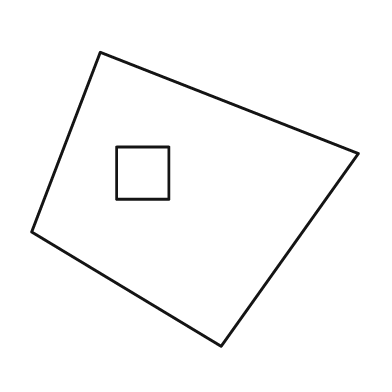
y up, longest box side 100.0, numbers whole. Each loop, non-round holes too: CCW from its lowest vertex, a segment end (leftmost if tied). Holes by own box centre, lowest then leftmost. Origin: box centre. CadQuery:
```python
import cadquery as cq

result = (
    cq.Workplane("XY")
    .moveTo(8.0, -45.0)
    .lineTo(50.0, 14.0)
    .lineTo(-29.0, 45.0)
    .lineTo(-50.0, -10.0)
    .close()
    .moveTo(-24.0, 0.0)
    .lineTo(-8.0, 0.0)
    .lineTo(-8.0, 16.0)
    .lineTo(-24.0, 16.0)
    .close()
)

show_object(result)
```